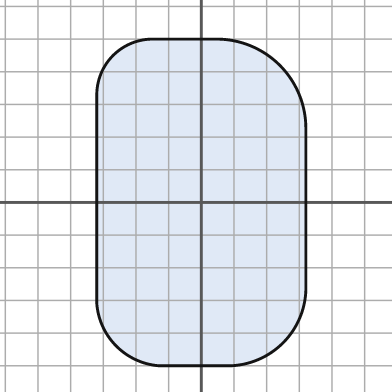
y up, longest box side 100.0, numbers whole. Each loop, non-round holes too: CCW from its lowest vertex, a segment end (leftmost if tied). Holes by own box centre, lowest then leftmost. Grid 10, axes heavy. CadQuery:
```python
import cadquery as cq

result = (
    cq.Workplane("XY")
    .moveTo(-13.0, -50.0)
    .lineTo(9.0, -50.0)
    .threePointArc((25.0, -43.0), (32.0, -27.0))
    .lineTo(32.0, 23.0)
    .threePointArc((24.0, 42.0), (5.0, 50.0))
    .lineTo(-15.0, 50.0)
    .threePointArc((-27.0, 45.0), (-32.0, 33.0))
    .lineTo(-32.0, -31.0)
    .threePointArc((-26.0, -44.0), (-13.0, -50.0))
    .close()
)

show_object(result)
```